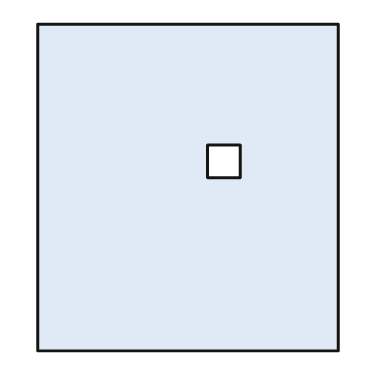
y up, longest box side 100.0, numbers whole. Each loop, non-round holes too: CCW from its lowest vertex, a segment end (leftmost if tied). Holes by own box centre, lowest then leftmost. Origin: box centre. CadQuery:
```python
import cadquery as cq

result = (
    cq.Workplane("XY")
    .moveTo(-46.0, -50.0)
    .lineTo(46.0, -50.0)
    .lineTo(46.0, 50.0)
    .lineTo(-46.0, 50.0)
    .close()
    .moveTo(6.0, 3.0)
    .lineTo(16.0, 3.0)
    .lineTo(16.0, 13.0)
    .lineTo(6.0, 13.0)
    .close()
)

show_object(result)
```